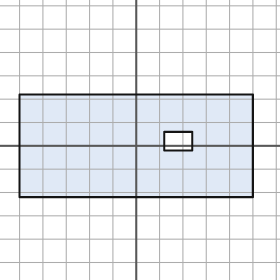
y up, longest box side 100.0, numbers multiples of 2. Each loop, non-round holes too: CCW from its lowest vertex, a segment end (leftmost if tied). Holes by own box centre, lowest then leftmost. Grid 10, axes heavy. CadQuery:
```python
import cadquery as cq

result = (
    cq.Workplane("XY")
    .moveTo(-50.0, -22.0)
    .lineTo(50.0, -22.0)
    .lineTo(50.0, 22.0)
    .lineTo(-50.0, 22.0)
    .close()
    .moveTo(12.0, -2.0)
    .lineTo(24.0, -2.0)
    .lineTo(24.0, 6.0)
    .lineTo(12.0, 6.0)
    .close()
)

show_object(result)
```